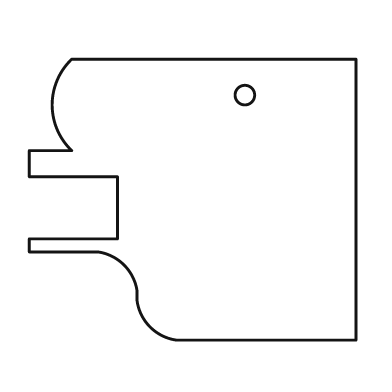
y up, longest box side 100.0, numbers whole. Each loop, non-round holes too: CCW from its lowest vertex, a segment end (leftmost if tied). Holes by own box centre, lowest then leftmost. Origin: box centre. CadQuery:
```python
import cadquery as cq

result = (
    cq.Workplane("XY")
    .moveTo(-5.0, -43.0)
    .lineTo(50.0, -43.0)
    .lineTo(50.0, 43.0)
    .lineTo(-37.0, 43.0)
    .threePointArc((-43.0, 29.0), (-37.0, 15.0))
    .lineTo(-50.0, 15.0)
    .lineTo(-50.0, 7.0)
    .lineTo(-23.0, 7.0)
    .lineTo(-23.0, -12.0)
    .lineTo(-50.0, -12.0)
    .lineTo(-50.0, -16.0)
    .lineTo(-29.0, -16.0)
    .threePointArc((-21.0, -20.0), (-17.0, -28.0))
    .lineTo(-17.0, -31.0)
    .threePointArc((-13.0, -39.0), (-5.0, -43.0))
    .close()
    .moveTo(16.0, 32.0)
    .circle(3.0)
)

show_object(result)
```